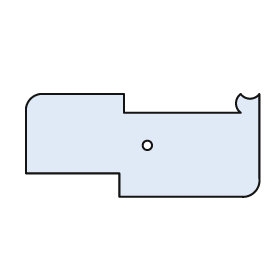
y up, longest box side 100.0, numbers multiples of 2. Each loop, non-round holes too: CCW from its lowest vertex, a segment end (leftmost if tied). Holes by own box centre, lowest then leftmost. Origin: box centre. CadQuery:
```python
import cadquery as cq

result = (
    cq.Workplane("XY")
    .moveTo(-10.0, -22.0)
    .lineTo(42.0, -22.0)
    .threePointArc((48.0, -20.0), (50.0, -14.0))
    .lineTo(50.0, 22.0)
    .threePointArc((46.0, 20.0), (42.0, 22.0))
    .threePointArc((40.0, 18.0), (42.0, 14.0))
    .lineTo(-8.0, 14.0)
    .lineTo(-8.0, 22.0)
    .lineTo(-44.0, 22.0)
    .threePointArc((-48.0, 20.0), (-50.0, 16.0))
    .lineTo(-50.0, -12.0)
    .lineTo(-10.0, -12.0)
    .close()
    .moveTo(2.0, 0.0)
    .circle(2.0)
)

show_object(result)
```